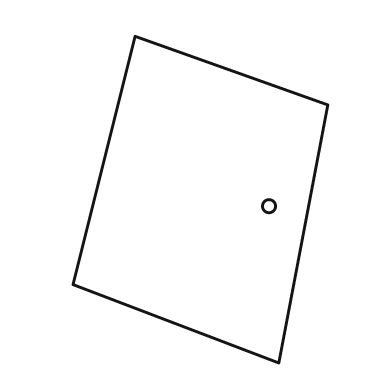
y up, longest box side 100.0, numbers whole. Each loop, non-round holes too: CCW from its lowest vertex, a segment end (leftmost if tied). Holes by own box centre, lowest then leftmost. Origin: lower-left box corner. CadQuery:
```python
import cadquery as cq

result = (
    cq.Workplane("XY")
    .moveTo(63.0, 0.0)
    .lineTo(78.0, 79.0)
    .lineTo(19.0, 100.0)
    .lineTo(0.0, 24.0)
    .close()
    .moveTo(60.0, 48.0)
    .circle(2.0)
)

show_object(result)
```